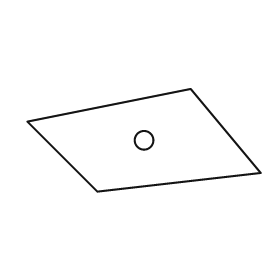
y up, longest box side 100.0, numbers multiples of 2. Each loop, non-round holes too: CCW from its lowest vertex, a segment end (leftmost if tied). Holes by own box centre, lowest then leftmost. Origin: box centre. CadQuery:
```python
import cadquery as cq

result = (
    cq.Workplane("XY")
    .moveTo(-20.0, -22.0)
    .lineTo(50.0, -14.0)
    .lineTo(20.0, 22.0)
    .lineTo(-50.0, 8.0)
    .close()
    .moveTo(0.0, 0.0)
    .circle(4.0)
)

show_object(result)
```